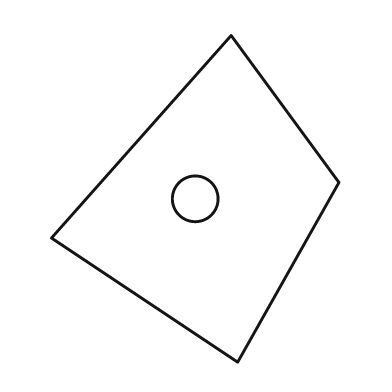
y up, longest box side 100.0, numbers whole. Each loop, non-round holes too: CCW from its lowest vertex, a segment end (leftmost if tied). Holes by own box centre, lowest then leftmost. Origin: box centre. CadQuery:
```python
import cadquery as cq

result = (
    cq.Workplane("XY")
    .moveTo(13.0, -50.0)
    .lineTo(44.0, 5.0)
    .lineTo(11.0, 50.0)
    .lineTo(-44.0, -12.0)
    .close()
    .moveTo(0.0, 0.0)
    .circle(7.0)
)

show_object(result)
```